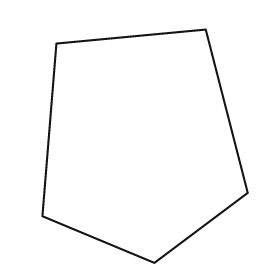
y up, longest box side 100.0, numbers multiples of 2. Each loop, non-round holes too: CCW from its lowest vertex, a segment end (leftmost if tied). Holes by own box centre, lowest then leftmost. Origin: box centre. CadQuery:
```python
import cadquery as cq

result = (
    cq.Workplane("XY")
    .moveTo(4.0, -50.0)
    .lineTo(44.0, -20.0)
    .lineTo(26.0, 50.0)
    .lineTo(-38.0, 44.0)
    .lineTo(-44.0, -30.0)
    .close()
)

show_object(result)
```